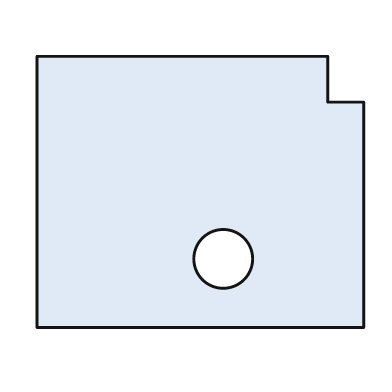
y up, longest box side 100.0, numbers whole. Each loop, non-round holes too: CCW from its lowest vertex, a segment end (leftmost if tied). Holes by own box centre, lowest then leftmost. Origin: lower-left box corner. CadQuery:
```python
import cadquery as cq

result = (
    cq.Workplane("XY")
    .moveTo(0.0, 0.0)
    .lineTo(100.0, 0.0)
    .lineTo(100.0, 69.0)
    .lineTo(89.0, 69.0)
    .lineTo(89.0, 83.0)
    .lineTo(0.0, 83.0)
    .close()
    .moveTo(57.0, 21.0)
    .circle(9.0)
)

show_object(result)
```